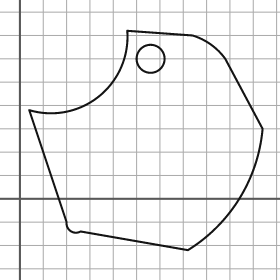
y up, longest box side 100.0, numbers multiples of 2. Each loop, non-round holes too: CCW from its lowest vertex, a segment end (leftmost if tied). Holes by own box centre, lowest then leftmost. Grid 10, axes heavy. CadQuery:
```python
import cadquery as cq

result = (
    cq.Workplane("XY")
    .moveTo(72.0, -22.0)
    .threePointArc((94.0, 0.0), (104.0, 30.0))
    .lineTo(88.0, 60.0)
    .threePointArc((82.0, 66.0), (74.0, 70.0))
    .lineTo(46.0, 72.0)
    .threePointArc((34.0, 44.0), (4.0, 38.0))
    .lineTo(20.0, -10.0)
    .threePointArc((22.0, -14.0), (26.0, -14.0))
    .close()
    .moveTo(56.0, 60.0)
    .circle(6.0)
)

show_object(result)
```